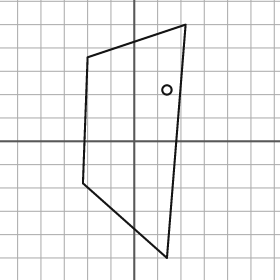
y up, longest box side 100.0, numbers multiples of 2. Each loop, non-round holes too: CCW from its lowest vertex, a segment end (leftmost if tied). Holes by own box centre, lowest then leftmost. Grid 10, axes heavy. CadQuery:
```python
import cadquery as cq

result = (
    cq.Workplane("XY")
    .moveTo(14.0, -50.0)
    .lineTo(22.0, 50.0)
    .lineTo(-20.0, 36.0)
    .lineTo(-22.0, -18.0)
    .close()
    .moveTo(14.0, 22.0)
    .circle(2.0)
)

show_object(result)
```